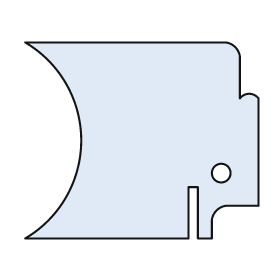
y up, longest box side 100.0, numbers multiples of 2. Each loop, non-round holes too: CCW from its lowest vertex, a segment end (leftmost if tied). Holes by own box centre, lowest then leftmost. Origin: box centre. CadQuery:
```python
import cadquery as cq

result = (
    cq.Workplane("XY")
    .moveTo(-50.0, -42.0)
    .lineTo(20.0, -42.0)
    .lineTo(20.0, -20.0)
    .lineTo(24.0, -20.0)
    .lineTo(24.0, -42.0)
    .lineTo(30.0, -42.0)
    .lineTo(30.0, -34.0)
    .threePointArc((32.0, -30.0), (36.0, -28.0))
    .lineTo(50.0, -28.0)
    .lineTo(50.0, 18.0)
    .threePointArc((46.0, 20.0), (42.0, 18.0))
    .lineTo(42.0, 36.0)
    .threePointArc((40.0, 40.0), (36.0, 42.0))
    .lineTo(-50.0, 42.0)
    .threePointArc((-26.0, 0.0), (-50.0, -42.0))
    .close()
    .moveTo(34.0, -14.0)
    .circle(4.0)
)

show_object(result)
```